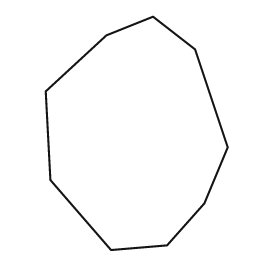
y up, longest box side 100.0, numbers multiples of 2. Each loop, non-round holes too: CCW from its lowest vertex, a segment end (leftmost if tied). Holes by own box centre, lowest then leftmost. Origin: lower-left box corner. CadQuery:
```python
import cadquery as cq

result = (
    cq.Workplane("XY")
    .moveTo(28.0, 0.0)
    .lineTo(52.0, 2.0)
    .lineTo(68.0, 20.0)
    .lineTo(78.0, 44.0)
    .lineTo(64.0, 86.0)
    .lineTo(46.0, 100.0)
    .lineTo(26.0, 92.0)
    .lineTo(0.0, 68.0)
    .lineTo(2.0, 30.0)
    .close()
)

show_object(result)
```